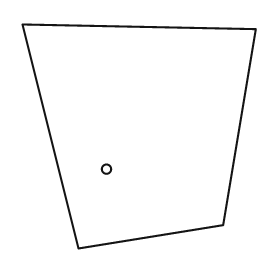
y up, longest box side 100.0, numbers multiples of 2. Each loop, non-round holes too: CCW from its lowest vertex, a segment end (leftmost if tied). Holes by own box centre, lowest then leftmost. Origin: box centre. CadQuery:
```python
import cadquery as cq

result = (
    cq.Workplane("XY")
    .moveTo(-26.0, -48.0)
    .lineTo(36.0, -38.0)
    .lineTo(50.0, 46.0)
    .lineTo(-50.0, 48.0)
    .close()
    .moveTo(-14.0, -14.0)
    .circle(2.0)
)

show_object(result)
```